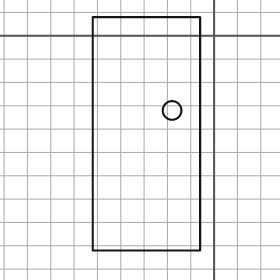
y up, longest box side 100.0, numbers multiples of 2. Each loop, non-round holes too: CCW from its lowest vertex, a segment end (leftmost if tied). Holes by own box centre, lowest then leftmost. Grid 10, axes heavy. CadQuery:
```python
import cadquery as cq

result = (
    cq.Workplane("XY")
    .moveTo(-52.0, -92.0)
    .lineTo(-6.0, -92.0)
    .lineTo(-6.0, 8.0)
    .lineTo(-52.0, 8.0)
    .close()
    .moveTo(-18.0, -32.0)
    .circle(4.0)
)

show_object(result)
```